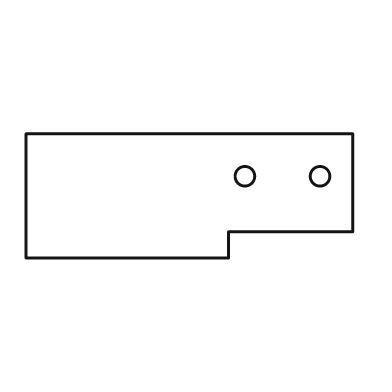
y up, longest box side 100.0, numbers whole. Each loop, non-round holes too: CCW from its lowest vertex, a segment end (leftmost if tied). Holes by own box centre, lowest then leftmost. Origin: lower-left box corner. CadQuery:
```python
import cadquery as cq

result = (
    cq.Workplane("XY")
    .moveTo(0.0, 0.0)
    .lineTo(62.0, 0.0)
    .lineTo(62.0, 8.0)
    .lineTo(100.0, 8.0)
    .lineTo(100.0, 38.0)
    .lineTo(0.0, 38.0)
    .close()
    .moveTo(67.0, 25.0)
    .circle(3.0)
    .moveTo(90.0, 25.0)
    .circle(3.0)
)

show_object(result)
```